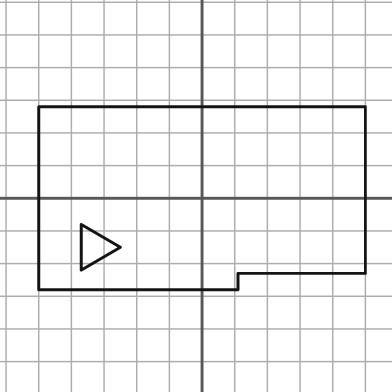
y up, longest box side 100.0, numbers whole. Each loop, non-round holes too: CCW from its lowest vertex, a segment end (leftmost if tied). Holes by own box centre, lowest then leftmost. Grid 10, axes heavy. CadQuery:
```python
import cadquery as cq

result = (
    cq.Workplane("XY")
    .moveTo(-50.0, -28.0)
    .lineTo(11.0, -28.0)
    .lineTo(11.0, -23.0)
    .lineTo(50.0, -23.0)
    .lineTo(50.0, 28.0)
    .lineTo(-50.0, 28.0)
    .close()
    .moveTo(-37.0, -22.0)
    .lineTo(-25.0, -15.0)
    .lineTo(-37.0, -8.0)
    .close()
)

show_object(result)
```